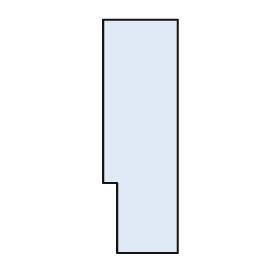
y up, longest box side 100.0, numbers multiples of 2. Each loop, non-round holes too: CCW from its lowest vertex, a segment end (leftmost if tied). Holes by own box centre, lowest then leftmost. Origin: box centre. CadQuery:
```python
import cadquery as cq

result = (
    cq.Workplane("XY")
    .moveTo(-10.0, -50.0)
    .lineTo(16.0, -50.0)
    .lineTo(16.0, 50.0)
    .lineTo(-16.0, 50.0)
    .lineTo(-16.0, -20.0)
    .lineTo(-10.0, -20.0)
    .close()
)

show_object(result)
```